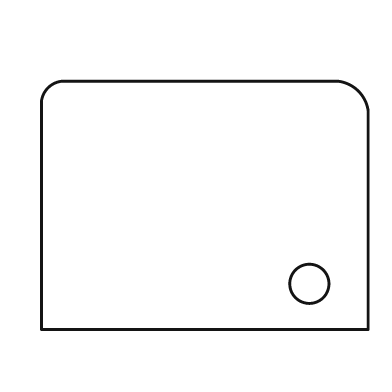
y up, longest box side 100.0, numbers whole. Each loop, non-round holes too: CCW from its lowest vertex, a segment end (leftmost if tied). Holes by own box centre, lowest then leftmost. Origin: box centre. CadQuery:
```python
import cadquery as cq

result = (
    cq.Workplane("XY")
    .moveTo(-50.0, -38.0)
    .lineTo(50.0, -38.0)
    .lineTo(50.0, 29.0)
    .threePointArc((47.0, 35.0), (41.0, 38.0))
    .lineTo(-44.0, 38.0)
    .threePointArc((-48.0, 36.0), (-50.0, 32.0))
    .close()
    .moveTo(32.0, -24.0)
    .circle(6.0)
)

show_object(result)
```